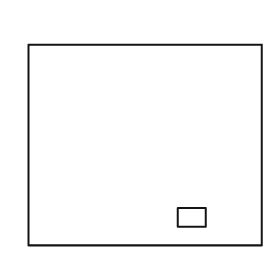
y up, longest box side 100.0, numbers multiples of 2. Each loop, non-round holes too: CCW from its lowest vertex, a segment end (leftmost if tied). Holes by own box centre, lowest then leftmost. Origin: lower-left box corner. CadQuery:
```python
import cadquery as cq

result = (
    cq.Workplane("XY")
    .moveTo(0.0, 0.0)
    .lineTo(100.0, 0.0)
    .lineTo(100.0, 86.0)
    .lineTo(0.0, 86.0)
    .close()
    .moveTo(64.0, 8.0)
    .lineTo(76.0, 8.0)
    .lineTo(76.0, 16.0)
    .lineTo(64.0, 16.0)
    .close()
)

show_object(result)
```